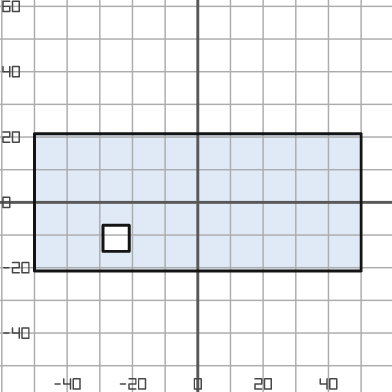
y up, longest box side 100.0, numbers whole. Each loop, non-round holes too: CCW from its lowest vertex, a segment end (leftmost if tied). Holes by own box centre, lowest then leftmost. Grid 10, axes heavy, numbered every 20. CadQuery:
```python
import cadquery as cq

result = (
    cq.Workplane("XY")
    .moveTo(-50.0, -21.0)
    .lineTo(50.0, -21.0)
    .lineTo(50.0, 21.0)
    .lineTo(-50.0, 21.0)
    .close()
    .moveTo(-29.0, -15.0)
    .lineTo(-21.0, -15.0)
    .lineTo(-21.0, -7.0)
    .lineTo(-29.0, -7.0)
    .close()
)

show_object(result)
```